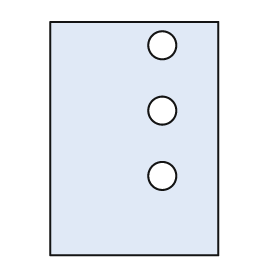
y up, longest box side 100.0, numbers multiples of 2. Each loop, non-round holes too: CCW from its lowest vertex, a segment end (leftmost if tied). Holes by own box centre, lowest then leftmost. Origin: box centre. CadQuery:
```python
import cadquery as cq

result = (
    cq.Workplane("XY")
    .moveTo(-36.0, -50.0)
    .lineTo(36.0, -50.0)
    .lineTo(36.0, 50.0)
    .lineTo(-36.0, 50.0)
    .close()
    .moveTo(12.0, -16.0)
    .circle(6.0)
    .moveTo(12.0, 12.0)
    .circle(6.0)
    .moveTo(12.0, 40.0)
    .circle(6.0)
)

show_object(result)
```